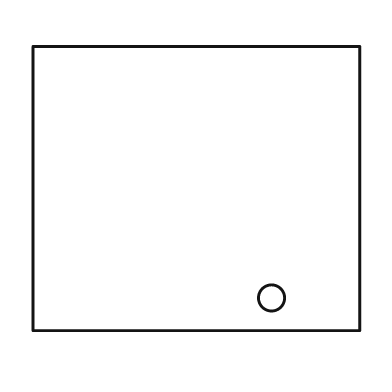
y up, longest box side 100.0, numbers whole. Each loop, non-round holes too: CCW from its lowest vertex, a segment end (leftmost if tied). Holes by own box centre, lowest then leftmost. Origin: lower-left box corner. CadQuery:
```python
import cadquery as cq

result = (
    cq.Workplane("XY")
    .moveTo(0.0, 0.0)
    .lineTo(100.0, 0.0)
    .lineTo(100.0, 87.0)
    .lineTo(0.0, 87.0)
    .close()
    .moveTo(73.0, 10.0)
    .circle(4.0)
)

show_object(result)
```